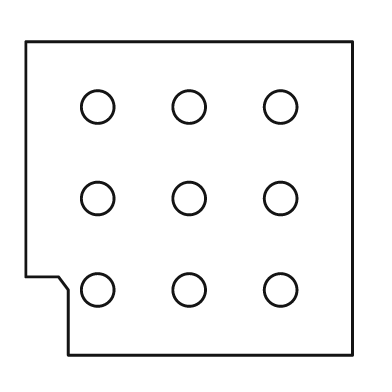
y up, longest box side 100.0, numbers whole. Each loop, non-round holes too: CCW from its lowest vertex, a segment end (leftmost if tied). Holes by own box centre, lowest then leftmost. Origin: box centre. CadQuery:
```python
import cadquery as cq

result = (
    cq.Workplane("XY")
    .moveTo(-37.0, -48.0)
    .lineTo(50.0, -48.0)
    .lineTo(50.0, 48.0)
    .lineTo(-50.0, 48.0)
    .lineTo(-50.0, -24.0)
    .lineTo(-40.0, -24.0)
    .lineTo(-37.0, -28.0)
    .close()
    .moveTo(-28.0, -28.0)
    .circle(5.0)
    .moveTo(0.0, -28.0)
    .circle(5.0)
    .moveTo(28.0, -28.0)
    .circle(5.0)
    .moveTo(-28.0, 0.0)
    .circle(5.0)
    .moveTo(0.0, 0.0)
    .circle(5.0)
    .moveTo(28.0, 0.0)
    .circle(5.0)
    .moveTo(-28.0, 28.0)
    .circle(5.0)
    .moveTo(0.0, 28.0)
    .circle(5.0)
    .moveTo(28.0, 28.0)
    .circle(5.0)
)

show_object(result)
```